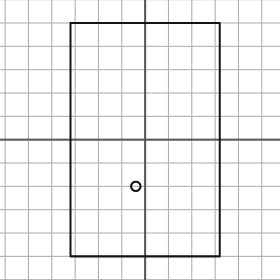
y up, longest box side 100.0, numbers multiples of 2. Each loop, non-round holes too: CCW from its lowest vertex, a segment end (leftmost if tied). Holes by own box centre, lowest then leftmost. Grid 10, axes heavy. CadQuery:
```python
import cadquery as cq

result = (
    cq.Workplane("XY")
    .moveTo(-32.0, -50.0)
    .lineTo(32.0, -50.0)
    .lineTo(32.0, 50.0)
    .lineTo(-32.0, 50.0)
    .close()
    .moveTo(-4.0, -20.0)
    .circle(2.0)
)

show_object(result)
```